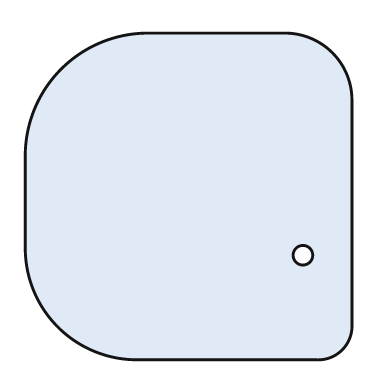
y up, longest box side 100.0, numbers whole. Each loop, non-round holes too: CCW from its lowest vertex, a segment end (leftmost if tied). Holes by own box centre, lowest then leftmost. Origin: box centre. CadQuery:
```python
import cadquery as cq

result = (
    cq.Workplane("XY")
    .moveTo(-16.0, -50.0)
    .lineTo(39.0, -50.0)
    .threePointArc((47.0, -47.0), (50.0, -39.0))
    .lineTo(50.0, 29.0)
    .threePointArc((44.0, 44.0), (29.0, 50.0))
    .lineTo(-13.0, 50.0)
    .threePointArc((-39.0, 39.0), (-50.0, 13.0))
    .lineTo(-50.0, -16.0)
    .threePointArc((-40.0, -40.0), (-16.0, -50.0))
    .close()
    .moveTo(35.0, -18.0)
    .circle(3.0)
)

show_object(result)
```